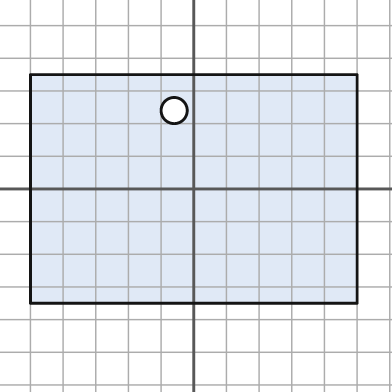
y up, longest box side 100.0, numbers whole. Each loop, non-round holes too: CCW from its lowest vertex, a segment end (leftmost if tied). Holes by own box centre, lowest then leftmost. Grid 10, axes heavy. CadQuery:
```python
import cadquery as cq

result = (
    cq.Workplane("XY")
    .moveTo(-50.0, -35.0)
    .lineTo(50.0, -35.0)
    .lineTo(50.0, 35.0)
    .lineTo(-50.0, 35.0)
    .close()
    .moveTo(-6.0, 24.0)
    .circle(4.0)
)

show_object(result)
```